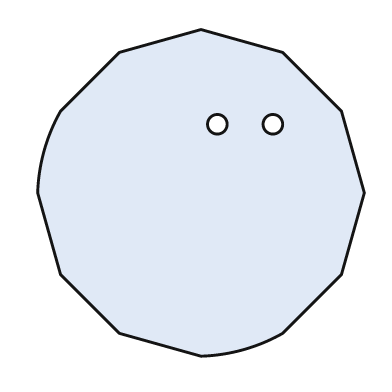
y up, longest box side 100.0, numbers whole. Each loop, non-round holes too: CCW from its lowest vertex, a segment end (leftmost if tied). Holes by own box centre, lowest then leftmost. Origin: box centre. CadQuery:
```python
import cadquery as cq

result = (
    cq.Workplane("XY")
    .moveTo(0.0, -50.0)
    .threePointArc((13.0, -48.0), (25.0, -43.0))
    .lineTo(43.0, -25.0)
    .lineTo(50.0, 0.0)
    .lineTo(43.0, 25.0)
    .lineTo(25.0, 43.0)
    .lineTo(0.0, 50.0)
    .lineTo(-25.0, 43.0)
    .lineTo(-43.0, 25.0)
    .threePointArc((-48.0, 13.0), (-50.0, 0.0))
    .lineTo(-43.0, -25.0)
    .lineTo(-25.0, -43.0)
    .close()
    .moveTo(5.0, 21.0)
    .circle(3.0)
    .moveTo(22.0, 21.0)
    .circle(3.0)
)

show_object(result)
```